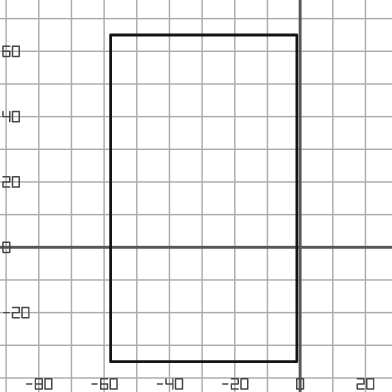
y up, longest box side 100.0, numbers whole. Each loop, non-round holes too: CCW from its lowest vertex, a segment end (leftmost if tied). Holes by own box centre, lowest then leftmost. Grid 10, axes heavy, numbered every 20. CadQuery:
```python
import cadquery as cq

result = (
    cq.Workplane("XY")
    .moveTo(-58.0, -35.0)
    .lineTo(-1.0, -35.0)
    .lineTo(-1.0, 65.0)
    .lineTo(-58.0, 65.0)
    .close()
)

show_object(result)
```